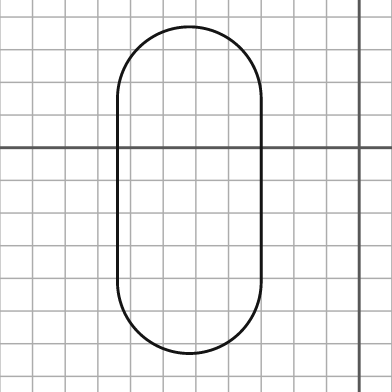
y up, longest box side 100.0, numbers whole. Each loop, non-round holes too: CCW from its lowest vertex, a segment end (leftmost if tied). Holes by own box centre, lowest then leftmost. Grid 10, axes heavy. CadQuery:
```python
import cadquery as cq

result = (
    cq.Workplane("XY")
    .moveTo(-74.0, -41.0)
    .threePointArc((-52.0, -63.0), (-30.0, -41.0))
    .lineTo(-30.0, 15.0)
    .threePointArc((-52.0, 37.0), (-74.0, 15.0))
    .close()
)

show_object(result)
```